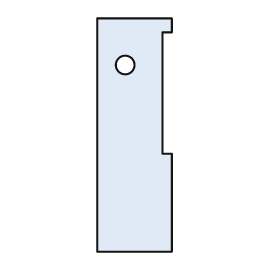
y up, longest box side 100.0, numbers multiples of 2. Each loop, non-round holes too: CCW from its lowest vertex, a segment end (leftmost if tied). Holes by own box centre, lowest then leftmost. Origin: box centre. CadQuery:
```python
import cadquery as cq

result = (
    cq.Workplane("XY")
    .moveTo(-16.0, -50.0)
    .lineTo(16.0, -50.0)
    .lineTo(16.0, -8.0)
    .lineTo(12.0, -8.0)
    .lineTo(12.0, 44.0)
    .lineTo(16.0, 44.0)
    .lineTo(16.0, 50.0)
    .lineTo(-16.0, 50.0)
    .close()
    .moveTo(-4.0, 30.0)
    .circle(4.0)
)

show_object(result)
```